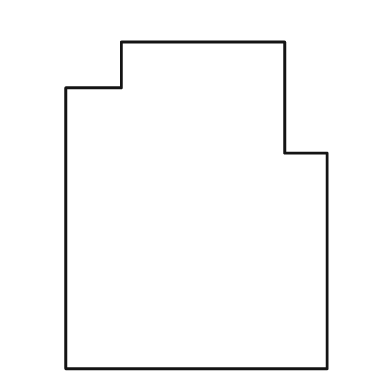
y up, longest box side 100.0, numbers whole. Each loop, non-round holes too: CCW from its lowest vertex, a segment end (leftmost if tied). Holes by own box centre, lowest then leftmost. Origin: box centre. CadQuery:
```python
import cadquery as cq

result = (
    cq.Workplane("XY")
    .moveTo(-40.0, -50.0)
    .lineTo(40.0, -50.0)
    .lineTo(40.0, 16.0)
    .lineTo(27.0, 16.0)
    .lineTo(27.0, 50.0)
    .lineTo(-23.0, 50.0)
    .lineTo(-23.0, 36.0)
    .lineTo(-40.0, 36.0)
    .close()
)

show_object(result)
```